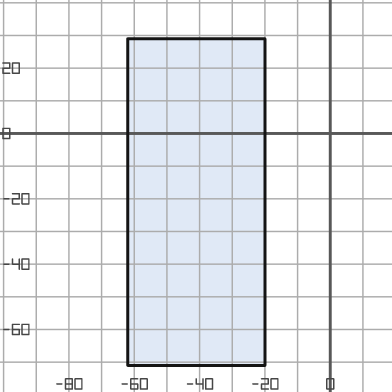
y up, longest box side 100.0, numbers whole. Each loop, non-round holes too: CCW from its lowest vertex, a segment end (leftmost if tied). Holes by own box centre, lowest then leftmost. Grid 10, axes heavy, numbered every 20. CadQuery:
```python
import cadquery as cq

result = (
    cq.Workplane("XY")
    .moveTo(-62.0, -71.0)
    .lineTo(-20.0, -71.0)
    .lineTo(-20.0, 29.0)
    .lineTo(-62.0, 29.0)
    .close()
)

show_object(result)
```